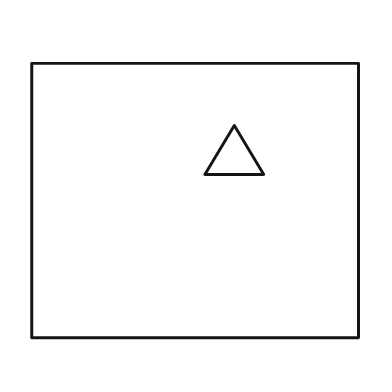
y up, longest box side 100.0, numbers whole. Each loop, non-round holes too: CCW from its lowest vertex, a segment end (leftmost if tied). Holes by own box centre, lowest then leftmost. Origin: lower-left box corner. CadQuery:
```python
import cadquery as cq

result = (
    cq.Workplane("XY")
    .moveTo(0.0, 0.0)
    .lineTo(100.0, 0.0)
    .lineTo(100.0, 84.0)
    .lineTo(0.0, 84.0)
    .close()
    .moveTo(53.0, 50.0)
    .lineTo(71.0, 50.0)
    .lineTo(62.0, 65.0)
    .close()
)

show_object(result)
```